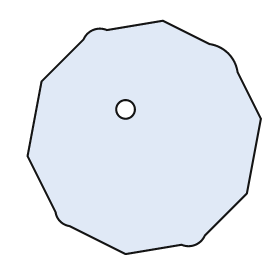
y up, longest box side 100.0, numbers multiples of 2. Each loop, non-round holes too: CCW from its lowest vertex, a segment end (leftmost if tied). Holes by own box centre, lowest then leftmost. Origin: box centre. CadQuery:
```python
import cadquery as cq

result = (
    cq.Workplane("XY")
    .moveTo(-8.0, -50.0)
    .lineTo(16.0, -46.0)
    .threePointArc((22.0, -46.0), (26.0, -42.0))
    .lineTo(44.0, -24.0)
    .lineTo(50.0, 8.0)
    .lineTo(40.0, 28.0)
    .threePointArc((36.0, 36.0), (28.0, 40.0))
    .lineTo(8.0, 50.0)
    .lineTo(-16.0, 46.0)
    .threePointArc((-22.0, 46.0), (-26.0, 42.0))
    .lineTo(-44.0, 24.0)
    .lineTo(-50.0, -8.0)
    .lineTo(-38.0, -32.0)
    .threePointArc((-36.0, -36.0), (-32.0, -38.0))
    .close()
    .moveTo(-8.0, 12.0)
    .circle(4.0)
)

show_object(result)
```